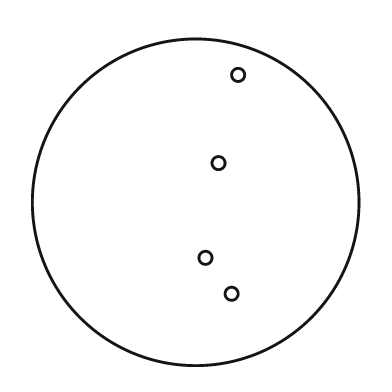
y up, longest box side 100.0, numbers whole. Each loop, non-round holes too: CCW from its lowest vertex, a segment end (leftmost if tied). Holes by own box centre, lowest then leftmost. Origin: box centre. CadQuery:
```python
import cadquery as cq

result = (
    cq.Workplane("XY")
    .moveTo(0.0, 0.0)
    .circle(50.0)
    .moveTo(11.0, -28.0)
    .circle(2.0)
    .moveTo(3.0, -17.0)
    .circle(2.0)
    .moveTo(7.0, 12.0)
    .circle(2.0)
    .moveTo(13.0, 39.0)
    .circle(2.0)
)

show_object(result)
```